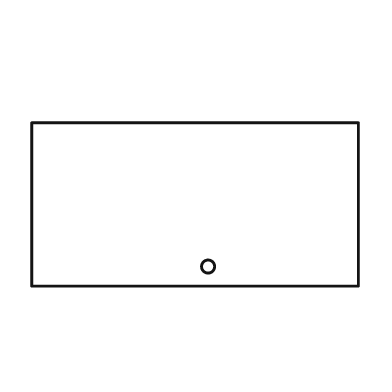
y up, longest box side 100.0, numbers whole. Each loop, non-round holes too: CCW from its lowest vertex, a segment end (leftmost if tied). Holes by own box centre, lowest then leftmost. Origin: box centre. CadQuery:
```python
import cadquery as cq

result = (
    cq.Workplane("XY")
    .moveTo(-50.0, -25.0)
    .lineTo(50.0, -25.0)
    .lineTo(50.0, 25.0)
    .lineTo(-50.0, 25.0)
    .close()
    .moveTo(4.0, -19.0)
    .circle(2.0)
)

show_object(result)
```